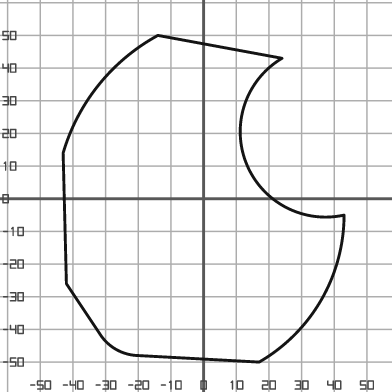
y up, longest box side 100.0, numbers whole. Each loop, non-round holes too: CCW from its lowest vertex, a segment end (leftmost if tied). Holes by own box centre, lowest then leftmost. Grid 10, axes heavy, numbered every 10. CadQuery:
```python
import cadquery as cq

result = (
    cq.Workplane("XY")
    .moveTo(17.0, -50.0)
    .threePointArc((36.0, -31.0), (43.0, -5.0))
    .threePointArc((13.0, 11.0), (24.0, 43.0))
    .lineTo(-14.0, 50.0)
    .threePointArc((-32.0, 35.0), (-43.0, 14.0))
    .lineTo(-42.0, -26.0)
    .lineTo(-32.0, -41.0)
    .threePointArc((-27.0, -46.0), (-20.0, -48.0))
    .close()
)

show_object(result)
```